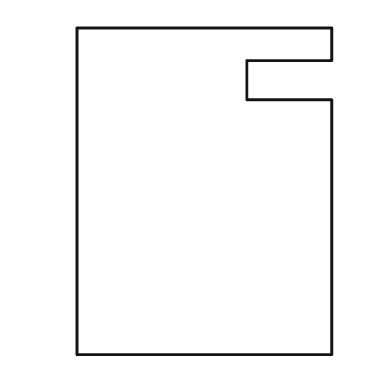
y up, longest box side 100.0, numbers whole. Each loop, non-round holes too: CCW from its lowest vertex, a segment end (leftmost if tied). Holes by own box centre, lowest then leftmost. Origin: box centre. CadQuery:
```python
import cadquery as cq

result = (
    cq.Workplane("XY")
    .moveTo(-39.0, -50.0)
    .lineTo(39.0, -50.0)
    .lineTo(39.0, 28.0)
    .lineTo(13.0, 28.0)
    .lineTo(13.0, 40.0)
    .lineTo(39.0, 40.0)
    .lineTo(39.0, 50.0)
    .lineTo(-39.0, 50.0)
    .close()
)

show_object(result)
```